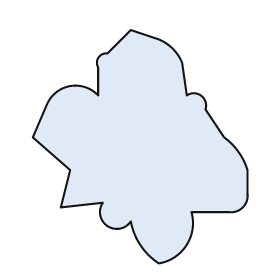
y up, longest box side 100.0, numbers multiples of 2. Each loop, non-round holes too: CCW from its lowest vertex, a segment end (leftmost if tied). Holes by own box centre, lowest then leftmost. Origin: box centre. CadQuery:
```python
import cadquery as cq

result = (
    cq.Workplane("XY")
    .moveTo(8.0, -50.0)
    .threePointArc((20.0, -42.0), (22.0, -28.0))
    .lineTo(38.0, -28.0)
    .threePointArc((44.0, -26.0), (46.0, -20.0))
    .lineTo(46.0, -10.0)
    .threePointArc((42.0, -2.0), (36.0, 4.0))
    .lineTo(28.0, 16.0)
    .threePointArc((26.0, 22.0), (20.0, 22.0))
    .lineTo(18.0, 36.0)
    .threePointArc((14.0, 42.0), (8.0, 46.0))
    .lineTo(-4.0, 50.0)
    .lineTo(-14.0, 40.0)
    .threePointArc((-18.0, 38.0), (-18.0, 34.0))
    .lineTo(-18.0, 22.0)
    .threePointArc((-30.0, 26.0), (-40.0, 18.0))
    .lineTo(-46.0, 4.0)
    .lineTo(-30.0, -10.0)
    .lineTo(-34.0, -26.0)
    .lineTo(-16.0, -24.0)
    .threePointArc((-14.0, -34.0), (-4.0, -32.0))
    .threePointArc((0.0, -42.0), (8.0, -50.0))
    .close()
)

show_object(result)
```